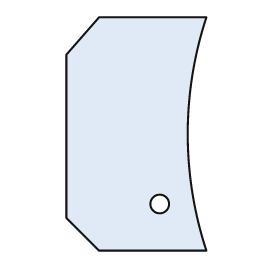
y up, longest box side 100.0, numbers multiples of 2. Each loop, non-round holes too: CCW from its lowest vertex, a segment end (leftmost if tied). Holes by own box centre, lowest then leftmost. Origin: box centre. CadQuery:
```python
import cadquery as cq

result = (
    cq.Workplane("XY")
    .moveTo(-16.0, -50.0)
    .lineTo(30.0, -50.0)
    .threePointArc((22.0, 0.0), (30.0, 50.0))
    .lineTo(-16.0, 50.0)
    .lineTo(-30.0, 34.0)
    .lineTo(-30.0, -36.0)
    .close()
    .moveTo(10.0, -30.0)
    .circle(4.0)
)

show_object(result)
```